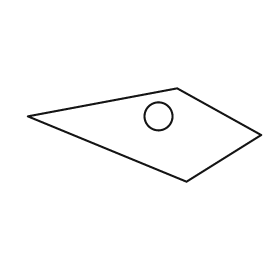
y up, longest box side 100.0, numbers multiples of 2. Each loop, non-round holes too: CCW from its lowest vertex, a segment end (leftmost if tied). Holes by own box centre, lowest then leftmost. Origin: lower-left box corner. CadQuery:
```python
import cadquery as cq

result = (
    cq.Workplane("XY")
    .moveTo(68.0, 0.0)
    .lineTo(100.0, 20.0)
    .lineTo(64.0, 40.0)
    .lineTo(0.0, 28.0)
    .close()
    .moveTo(56.0, 28.0)
    .circle(6.0)
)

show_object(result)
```